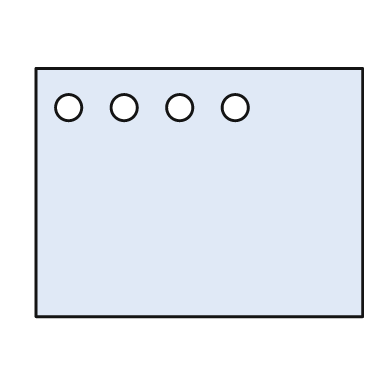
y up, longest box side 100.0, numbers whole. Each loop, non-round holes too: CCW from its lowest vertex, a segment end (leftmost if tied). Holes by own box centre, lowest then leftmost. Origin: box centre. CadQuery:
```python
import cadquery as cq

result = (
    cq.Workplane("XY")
    .moveTo(-50.0, -38.0)
    .lineTo(50.0, -38.0)
    .lineTo(50.0, 38.0)
    .lineTo(-50.0, 38.0)
    .close()
    .moveTo(-40.0, 26.0)
    .circle(4.0)
    .moveTo(-23.0, 26.0)
    .circle(4.0)
    .moveTo(-6.0, 26.0)
    .circle(4.0)
    .moveTo(11.0, 26.0)
    .circle(4.0)
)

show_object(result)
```